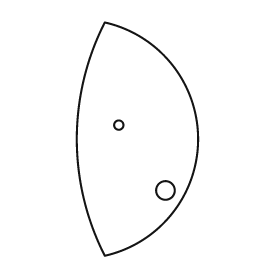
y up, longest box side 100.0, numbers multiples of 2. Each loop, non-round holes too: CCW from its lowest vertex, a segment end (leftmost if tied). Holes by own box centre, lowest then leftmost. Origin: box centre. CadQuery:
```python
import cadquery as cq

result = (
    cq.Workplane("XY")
    .moveTo(-14.0, -50.0)
    .threePointArc((26.0, 0.0), (-14.0, 50.0))
    .threePointArc((-26.0, 0.0), (-14.0, -50.0))
    .close()
    .moveTo(12.0, -22.0)
    .circle(4.0)
    .moveTo(-8.0, 6.0)
    .circle(2.0)
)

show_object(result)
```